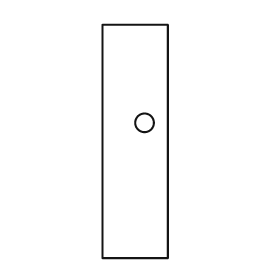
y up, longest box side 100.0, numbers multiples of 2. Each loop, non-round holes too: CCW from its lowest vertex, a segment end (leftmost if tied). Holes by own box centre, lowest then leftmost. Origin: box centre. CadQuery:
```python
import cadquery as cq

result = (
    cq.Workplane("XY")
    .moveTo(-14.0, -50.0)
    .lineTo(14.0, -50.0)
    .lineTo(14.0, 50.0)
    .lineTo(-14.0, 50.0)
    .close()
    .moveTo(4.0, 8.0)
    .circle(4.0)
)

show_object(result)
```